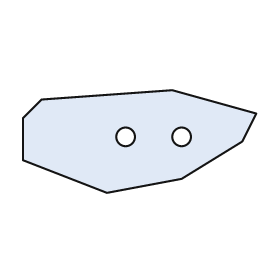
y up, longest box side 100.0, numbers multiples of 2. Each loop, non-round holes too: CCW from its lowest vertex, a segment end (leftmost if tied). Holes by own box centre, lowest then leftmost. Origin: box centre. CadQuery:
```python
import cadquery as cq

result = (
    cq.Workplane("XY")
    .moveTo(-14.0, -22.0)
    .lineTo(18.0, -16.0)
    .lineTo(44.0, 0.0)
    .lineTo(50.0, 12.0)
    .lineTo(14.0, 22.0)
    .lineTo(-42.0, 18.0)
    .lineTo(-50.0, 10.0)
    .lineTo(-50.0, -8.0)
    .close()
    .moveTo(-6.0, 2.0)
    .circle(4.0)
    .moveTo(18.0, 2.0)
    .circle(4.0)
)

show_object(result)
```